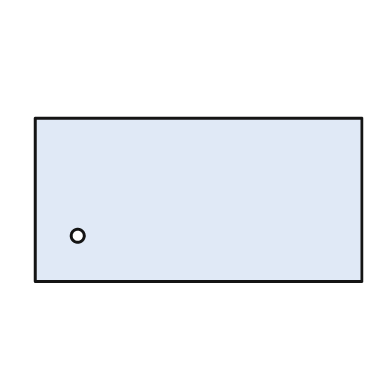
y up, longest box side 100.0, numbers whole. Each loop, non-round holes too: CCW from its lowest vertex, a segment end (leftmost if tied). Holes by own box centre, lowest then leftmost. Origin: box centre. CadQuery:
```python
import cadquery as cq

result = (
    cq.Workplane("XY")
    .moveTo(-50.0, -25.0)
    .lineTo(50.0, -25.0)
    .lineTo(50.0, 25.0)
    .lineTo(-50.0, 25.0)
    .close()
    .moveTo(-37.0, -11.0)
    .circle(2.0)
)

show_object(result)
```